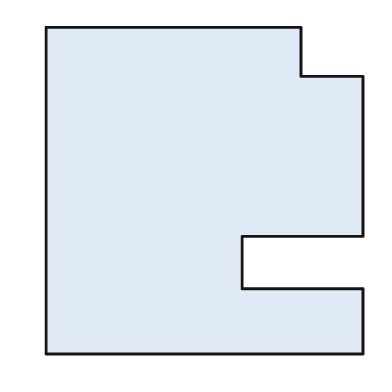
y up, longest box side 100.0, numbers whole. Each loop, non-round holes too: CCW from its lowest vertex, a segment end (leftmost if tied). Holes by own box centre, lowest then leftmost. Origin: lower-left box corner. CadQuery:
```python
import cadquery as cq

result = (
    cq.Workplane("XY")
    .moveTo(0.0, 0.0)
    .lineTo(97.0, 0.0)
    .lineTo(97.0, 20.0)
    .lineTo(60.0, 20.0)
    .lineTo(60.0, 36.0)
    .lineTo(97.0, 36.0)
    .lineTo(97.0, 85.0)
    .lineTo(78.0, 85.0)
    .lineTo(78.0, 100.0)
    .lineTo(0.0, 100.0)
    .close()
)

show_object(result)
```